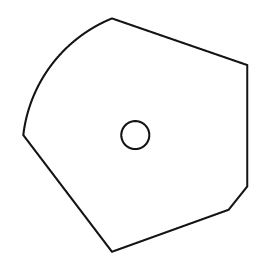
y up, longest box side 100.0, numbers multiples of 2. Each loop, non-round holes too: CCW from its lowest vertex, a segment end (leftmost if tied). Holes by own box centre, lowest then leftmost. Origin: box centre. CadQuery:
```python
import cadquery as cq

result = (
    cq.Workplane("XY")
    .moveTo(-10.0, -50.0)
    .lineTo(40.0, -32.0)
    .lineTo(48.0, -22.0)
    .lineTo(48.0, 30.0)
    .lineTo(-10.0, 50.0)
    .threePointArc((-36.0, 30.0), (-48.0, 0.0))
    .close()
    .moveTo(0.0, 0.0)
    .circle(6.0)
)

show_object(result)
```